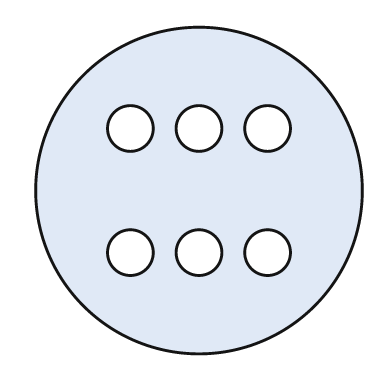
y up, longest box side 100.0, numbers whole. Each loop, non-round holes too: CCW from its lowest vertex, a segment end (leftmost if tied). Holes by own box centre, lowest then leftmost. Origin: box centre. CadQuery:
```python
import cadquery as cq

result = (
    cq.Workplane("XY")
    .moveTo(0.0, 0.0)
    .circle(50.0)
    .moveTo(-21.0, -19.0)
    .circle(7.0)
    .moveTo(0.0, -19.0)
    .circle(7.0)
    .moveTo(21.0, -19.0)
    .circle(7.0)
    .moveTo(-21.0, 19.0)
    .circle(7.0)
    .moveTo(0.0, 19.0)
    .circle(7.0)
    .moveTo(21.0, 19.0)
    .circle(7.0)
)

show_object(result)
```